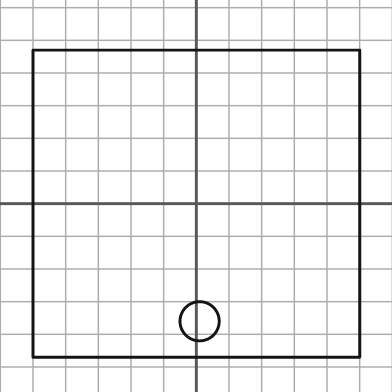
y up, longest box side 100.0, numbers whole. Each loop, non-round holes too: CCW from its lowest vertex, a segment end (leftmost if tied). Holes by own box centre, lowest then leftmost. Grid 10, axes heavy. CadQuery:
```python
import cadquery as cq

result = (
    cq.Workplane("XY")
    .moveTo(-50.0, -47.0)
    .lineTo(50.0, -47.0)
    .lineTo(50.0, 47.0)
    .lineTo(-50.0, 47.0)
    .close()
    .moveTo(1.0, -36.0)
    .circle(6.0)
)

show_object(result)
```